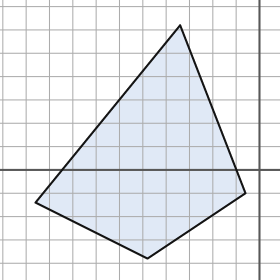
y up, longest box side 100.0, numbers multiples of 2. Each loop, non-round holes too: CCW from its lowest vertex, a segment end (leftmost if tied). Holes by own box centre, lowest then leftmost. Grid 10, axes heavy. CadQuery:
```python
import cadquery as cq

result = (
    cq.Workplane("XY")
    .moveTo(-48.0, -38.0)
    .lineTo(-6.0, -10.0)
    .lineTo(-34.0, 62.0)
    .lineTo(-96.0, -14.0)
    .close()
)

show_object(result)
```